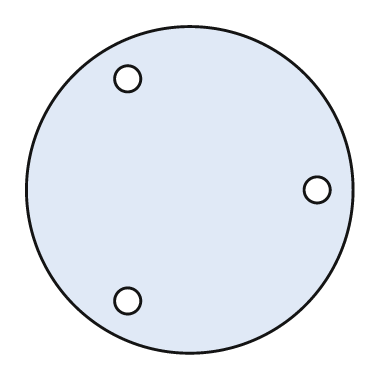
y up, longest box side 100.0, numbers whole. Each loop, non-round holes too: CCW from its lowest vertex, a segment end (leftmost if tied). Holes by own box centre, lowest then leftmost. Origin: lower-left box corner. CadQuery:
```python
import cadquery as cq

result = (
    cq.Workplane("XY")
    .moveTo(50.0, 50.0)
    .circle(50.0)
    .moveTo(31.0, 16.0)
    .circle(4.0)
    .moveTo(89.0, 50.0)
    .circle(4.0)
    .moveTo(31.0, 84.0)
    .circle(4.0)
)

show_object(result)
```